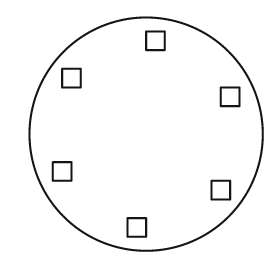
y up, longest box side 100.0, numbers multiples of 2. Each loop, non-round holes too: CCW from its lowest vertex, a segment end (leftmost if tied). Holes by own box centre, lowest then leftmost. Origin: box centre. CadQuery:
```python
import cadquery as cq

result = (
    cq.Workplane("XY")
    .moveTo(0.0, 0.0)
    .circle(50.0)
    .moveTo(-8.0, -44.0)
    .lineTo(0.0, -44.0)
    .lineTo(0.0, -36.0)
    .lineTo(-8.0, -36.0)
    .close()
    .moveTo(28.0, -28.0)
    .lineTo(36.0, -28.0)
    .lineTo(36.0, -20.0)
    .lineTo(28.0, -20.0)
    .close()
    .moveTo(-40.0, -20.0)
    .lineTo(-32.0, -20.0)
    .lineTo(-32.0, -12.0)
    .lineTo(-40.0, -12.0)
    .close()
    .moveTo(32.0, 12.0)
    .lineTo(40.0, 12.0)
    .lineTo(40.0, 20.0)
    .lineTo(32.0, 20.0)
    .close()
    .moveTo(-36.0, 20.0)
    .lineTo(-28.0, 20.0)
    .lineTo(-28.0, 28.0)
    .lineTo(-36.0, 28.0)
    .close()
    .moveTo(0.0, 36.0)
    .lineTo(8.0, 36.0)
    .lineTo(8.0, 44.0)
    .lineTo(0.0, 44.0)
    .close()
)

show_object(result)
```